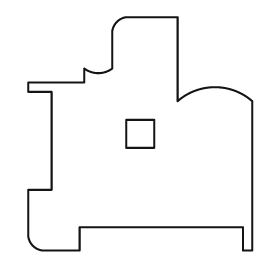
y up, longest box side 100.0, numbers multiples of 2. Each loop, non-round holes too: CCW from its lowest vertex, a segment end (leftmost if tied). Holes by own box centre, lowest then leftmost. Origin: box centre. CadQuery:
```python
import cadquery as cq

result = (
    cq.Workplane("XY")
    .moveTo(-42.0, -50.0)
    .lineTo(-26.0, -50.0)
    .lineTo(-26.0, -40.0)
    .lineTo(44.0, -40.0)
    .lineTo(44.0, -50.0)
    .lineTo(48.0, -50.0)
    .lineTo(48.0, 14.0)
    .threePointArc((32.0, 20.0), (16.0, 14.0))
    .lineTo(16.0, 50.0)
    .lineTo(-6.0, 50.0)
    .threePointArc((-10.0, 48.0), (-12.0, 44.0))
    .lineTo(-12.0, 28.0)
    .threePointArc((-18.0, 26.0), (-24.0, 28.0))
    .lineTo(-24.0, 22.0)
    .lineTo(-48.0, 22.0)
    .lineTo(-48.0, 18.0)
    .lineTo(-38.0, 18.0)
    .lineTo(-38.0, -24.0)
    .lineTo(-48.0, -24.0)
    .lineTo(-48.0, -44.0)
    .threePointArc((-46.0, -48.0), (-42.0, -50.0))
    .close()
    .moveTo(-6.0, -6.0)
    .lineTo(6.0, -6.0)
    .lineTo(6.0, 6.0)
    .lineTo(-6.0, 6.0)
    .close()
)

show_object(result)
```